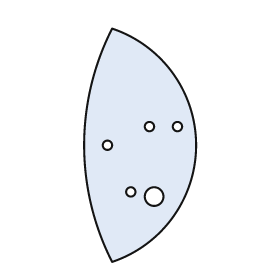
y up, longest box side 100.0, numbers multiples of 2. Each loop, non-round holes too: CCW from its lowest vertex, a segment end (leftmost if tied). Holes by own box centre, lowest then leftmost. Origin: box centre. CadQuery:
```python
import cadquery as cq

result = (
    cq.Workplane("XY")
    .moveTo(-12.0, -50.0)
    .threePointArc((24.0, 0.0), (-12.0, 50.0))
    .threePointArc((-24.0, 0.0), (-12.0, -50.0))
    .close()
    .moveTo(6.0, -22.0)
    .circle(4.0)
    .moveTo(-4.0, -20.0)
    .circle(2.0)
    .moveTo(-14.0, 0.0)
    .circle(2.0)
    .moveTo(4.0, 8.0)
    .circle(2.0)
    .moveTo(16.0, 8.0)
    .circle(2.0)
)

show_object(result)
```